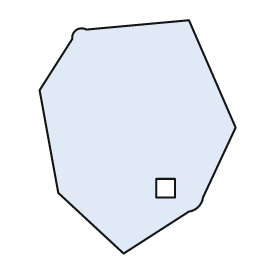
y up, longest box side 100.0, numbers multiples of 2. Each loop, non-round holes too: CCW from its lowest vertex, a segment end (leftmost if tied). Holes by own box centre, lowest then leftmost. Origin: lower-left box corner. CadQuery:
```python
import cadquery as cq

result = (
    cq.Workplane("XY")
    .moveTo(36.0, 0.0)
    .lineTo(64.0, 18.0)
    .threePointArc((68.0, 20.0), (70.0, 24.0))
    .lineTo(84.0, 54.0)
    .lineTo(64.0, 100.0)
    .lineTo(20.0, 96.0)
    .threePointArc((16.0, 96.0), (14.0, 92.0))
    .lineTo(0.0, 70.0)
    .lineTo(8.0, 26.0)
    .close()
    .moveTo(50.0, 24.0)
    .lineTo(58.0, 24.0)
    .lineTo(58.0, 32.0)
    .lineTo(50.0, 32.0)
    .close()
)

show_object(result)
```